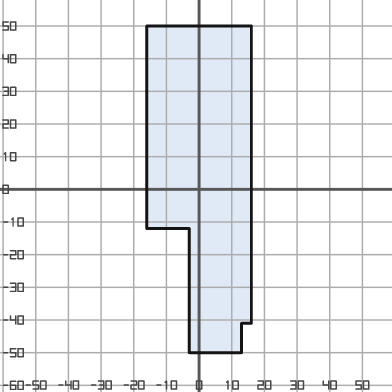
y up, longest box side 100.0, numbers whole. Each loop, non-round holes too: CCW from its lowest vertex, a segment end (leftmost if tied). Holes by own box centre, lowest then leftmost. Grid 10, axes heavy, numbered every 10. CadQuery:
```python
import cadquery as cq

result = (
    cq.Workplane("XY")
    .moveTo(-3.0, -50.0)
    .lineTo(13.0, -50.0)
    .lineTo(13.0, -41.0)
    .lineTo(16.0, -41.0)
    .lineTo(16.0, 50.0)
    .lineTo(-16.0, 50.0)
    .lineTo(-16.0, -12.0)
    .lineTo(-3.0, -12.0)
    .close()
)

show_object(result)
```